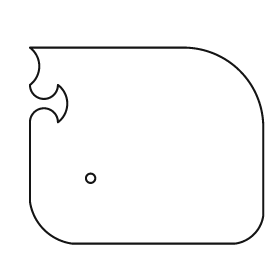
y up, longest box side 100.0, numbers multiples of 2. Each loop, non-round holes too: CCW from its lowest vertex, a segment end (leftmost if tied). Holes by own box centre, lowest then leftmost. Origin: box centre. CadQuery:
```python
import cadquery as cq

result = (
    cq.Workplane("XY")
    .moveTo(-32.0, -42.0)
    .lineTo(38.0, -42.0)
    .threePointArc((46.0, -38.0), (50.0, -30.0))
    .lineTo(50.0, 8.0)
    .threePointArc((40.0, 32.0), (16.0, 42.0))
    .lineTo(-50.0, 42.0)
    .threePointArc((-46.0, 34.0), (-50.0, 26.0))
    .threePointArc((-44.0, 20.0), (-38.0, 26.0))
    .threePointArc((-34.0, 18.0), (-38.0, 10.0))
    .threePointArc((-44.0, 16.0), (-50.0, 10.0))
    .lineTo(-50.0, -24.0)
    .threePointArc((-44.0, -36.0), (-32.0, -42.0))
    .close()
    .moveTo(-24.0, -14.0)
    .circle(2.0)
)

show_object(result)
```